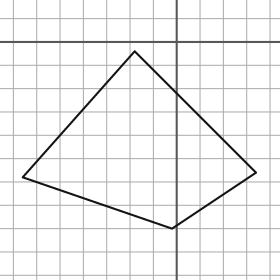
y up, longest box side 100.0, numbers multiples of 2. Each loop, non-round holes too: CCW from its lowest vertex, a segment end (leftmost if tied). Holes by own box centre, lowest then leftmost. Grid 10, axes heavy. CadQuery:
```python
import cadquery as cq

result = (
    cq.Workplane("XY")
    .moveTo(-2.0, -80.0)
    .lineTo(34.0, -56.0)
    .lineTo(-18.0, -4.0)
    .lineTo(-66.0, -58.0)
    .close()
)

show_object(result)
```